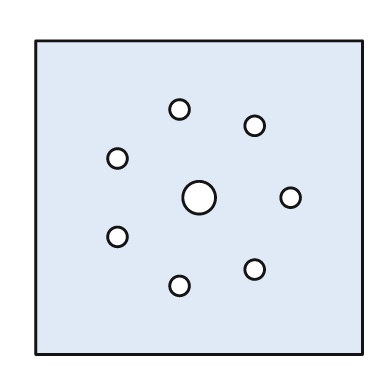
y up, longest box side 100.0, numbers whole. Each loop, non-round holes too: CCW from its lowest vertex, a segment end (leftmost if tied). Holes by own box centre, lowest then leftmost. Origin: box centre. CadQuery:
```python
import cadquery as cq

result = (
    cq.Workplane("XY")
    .moveTo(-50.0, -48.0)
    .lineTo(50.0, -48.0)
    .lineTo(50.0, 48.0)
    .lineTo(-50.0, 48.0)
    .close()
    .moveTo(-6.0, -27.0)
    .circle(3.0)
    .moveTo(17.0, -22.0)
    .circle(3.0)
    .moveTo(-25.0, -12.0)
    .circle(3.0)
    .moveTo(0.0, 0.0)
    .circle(5.0)
    .moveTo(28.0, 0.0)
    .circle(3.0)
    .moveTo(-25.0, 12.0)
    .circle(3.0)
    .moveTo(17.0, 22.0)
    .circle(3.0)
    .moveTo(-6.0, 27.0)
    .circle(3.0)
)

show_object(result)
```